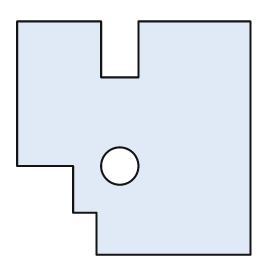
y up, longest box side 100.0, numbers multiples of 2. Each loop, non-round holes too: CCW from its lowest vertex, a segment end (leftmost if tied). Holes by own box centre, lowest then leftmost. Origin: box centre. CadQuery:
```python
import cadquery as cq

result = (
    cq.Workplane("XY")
    .moveTo(-16.0, -50.0)
    .lineTo(50.0, -50.0)
    .lineTo(50.0, 50.0)
    .lineTo(2.0, 50.0)
    .lineTo(2.0, 26.0)
    .lineTo(-14.0, 26.0)
    .lineTo(-14.0, 50.0)
    .lineTo(-50.0, 50.0)
    .lineTo(-50.0, -12.0)
    .lineTo(-26.0, -12.0)
    .lineTo(-26.0, -32.0)
    .lineTo(-16.0, -32.0)
    .close()
    .moveTo(-6.0, -12.0)
    .circle(8.0)
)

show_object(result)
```